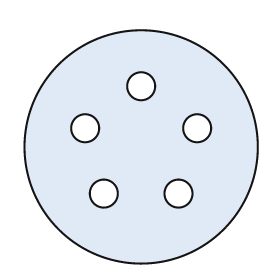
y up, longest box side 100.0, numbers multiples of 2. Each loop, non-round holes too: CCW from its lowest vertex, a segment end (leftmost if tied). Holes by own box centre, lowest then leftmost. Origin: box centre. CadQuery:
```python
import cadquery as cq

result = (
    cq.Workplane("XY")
    .moveTo(0.0, 0.0)
    .circle(50.0)
    .moveTo(-16.0, -20.0)
    .circle(6.0)
    .moveTo(16.0, -20.0)
    .circle(6.0)
    .moveTo(-24.0, 8.0)
    .circle(6.0)
    .moveTo(24.0, 8.0)
    .circle(6.0)
    .moveTo(0.0, 26.0)
    .circle(6.0)
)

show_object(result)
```